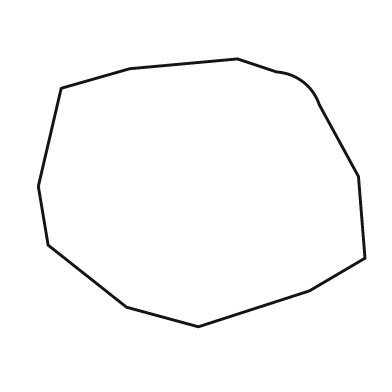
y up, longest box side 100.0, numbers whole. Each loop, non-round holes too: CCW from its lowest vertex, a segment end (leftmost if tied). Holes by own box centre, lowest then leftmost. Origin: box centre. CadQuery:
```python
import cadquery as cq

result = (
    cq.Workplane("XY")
    .moveTo(-1.0, -41.0)
    .lineTo(33.0, -30.0)
    .lineTo(50.0, -20.0)
    .lineTo(48.0, 5.0)
    .lineTo(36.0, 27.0)
    .threePointArc((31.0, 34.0), (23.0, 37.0))
    .lineTo(11.0, 41.0)
    .lineTo(-22.0, 38.0)
    .lineTo(-43.0, 32.0)
    .lineTo(-50.0, 2.0)
    .lineTo(-47.0, -16.0)
    .lineTo(-23.0, -35.0)
    .close()
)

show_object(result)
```